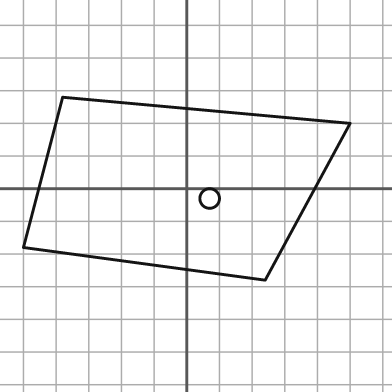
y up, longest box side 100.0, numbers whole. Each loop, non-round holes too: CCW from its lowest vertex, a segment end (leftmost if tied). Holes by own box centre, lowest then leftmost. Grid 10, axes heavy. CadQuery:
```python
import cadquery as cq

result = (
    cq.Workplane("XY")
    .moveTo(24.0, -28.0)
    .lineTo(50.0, 20.0)
    .lineTo(-38.0, 28.0)
    .lineTo(-50.0, -18.0)
    .close()
    .moveTo(7.0, -3.0)
    .circle(3.0)
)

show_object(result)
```